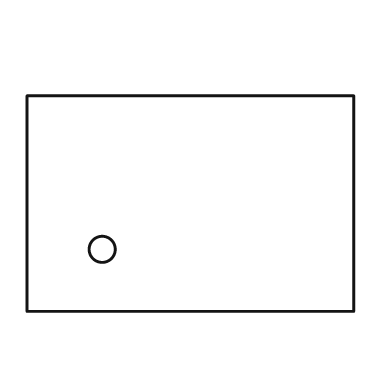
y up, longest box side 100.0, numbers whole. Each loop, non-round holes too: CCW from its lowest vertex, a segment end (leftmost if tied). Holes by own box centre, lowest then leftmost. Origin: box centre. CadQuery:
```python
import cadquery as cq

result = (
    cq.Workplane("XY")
    .moveTo(-50.0, -33.0)
    .lineTo(50.0, -33.0)
    .lineTo(50.0, 33.0)
    .lineTo(-50.0, 33.0)
    .close()
    .moveTo(-27.0, -14.0)
    .circle(4.0)
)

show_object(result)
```